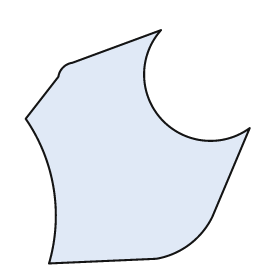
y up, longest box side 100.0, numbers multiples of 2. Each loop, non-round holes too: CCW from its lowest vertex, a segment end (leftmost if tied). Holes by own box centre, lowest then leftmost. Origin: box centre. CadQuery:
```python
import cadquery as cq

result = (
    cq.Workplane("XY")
    .moveTo(-38.0, -50.0)
    .lineTo(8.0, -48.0)
    .threePointArc((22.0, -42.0), (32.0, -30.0))
    .lineTo(48.0, 8.0)
    .threePointArc((10.0, 12.0), (10.0, 50.0))
    .lineTo(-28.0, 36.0)
    .threePointArc((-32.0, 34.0), (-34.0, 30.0))
    .lineTo(-48.0, 12.0)
    .threePointArc((-36.0, -18.0), (-38.0, -50.0))
    .close()
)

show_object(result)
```